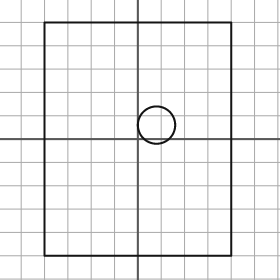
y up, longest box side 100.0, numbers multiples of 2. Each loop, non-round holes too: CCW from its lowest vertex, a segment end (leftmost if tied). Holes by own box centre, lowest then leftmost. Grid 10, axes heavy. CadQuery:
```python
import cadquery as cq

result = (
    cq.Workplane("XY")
    .moveTo(-40.0, -50.0)
    .lineTo(40.0, -50.0)
    .lineTo(40.0, 50.0)
    .lineTo(-40.0, 50.0)
    .close()
    .moveTo(8.0, 6.0)
    .circle(8.0)
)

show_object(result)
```